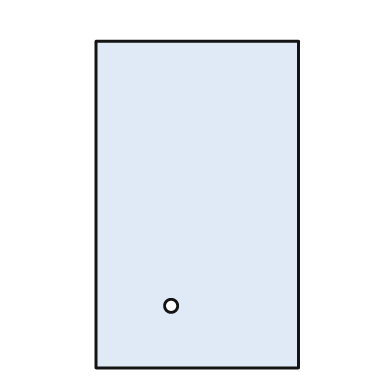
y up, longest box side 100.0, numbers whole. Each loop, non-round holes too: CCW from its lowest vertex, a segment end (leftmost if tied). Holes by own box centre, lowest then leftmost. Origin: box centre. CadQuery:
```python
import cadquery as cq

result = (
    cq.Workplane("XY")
    .moveTo(-31.0, -50.0)
    .lineTo(31.0, -50.0)
    .lineTo(31.0, 50.0)
    .lineTo(-31.0, 50.0)
    .close()
    .moveTo(-8.0, -31.0)
    .circle(2.0)
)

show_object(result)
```